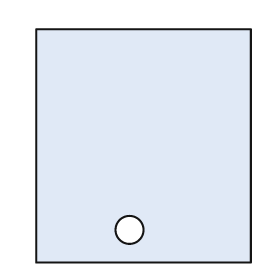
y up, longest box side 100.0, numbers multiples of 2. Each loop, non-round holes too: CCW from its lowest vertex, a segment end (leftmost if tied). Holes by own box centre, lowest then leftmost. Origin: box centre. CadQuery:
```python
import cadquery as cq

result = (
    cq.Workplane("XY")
    .moveTo(-46.0, -50.0)
    .lineTo(46.0, -50.0)
    .lineTo(46.0, 50.0)
    .lineTo(-46.0, 50.0)
    .close()
    .moveTo(-6.0, -36.0)
    .circle(6.0)
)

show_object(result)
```